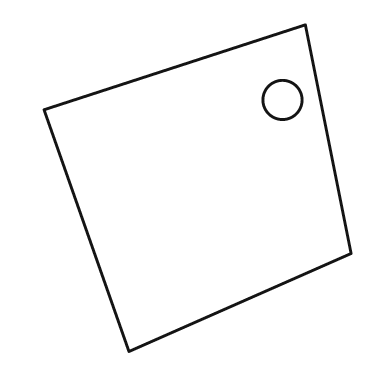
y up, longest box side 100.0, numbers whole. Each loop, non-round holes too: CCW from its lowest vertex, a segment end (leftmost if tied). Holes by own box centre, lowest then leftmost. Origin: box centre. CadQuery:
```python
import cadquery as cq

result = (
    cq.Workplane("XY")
    .moveTo(-21.0, -50.0)
    .lineTo(47.0, -20.0)
    .lineTo(33.0, 50.0)
    .lineTo(-47.0, 24.0)
    .close()
    .moveTo(26.0, 27.0)
    .circle(6.0)
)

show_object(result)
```